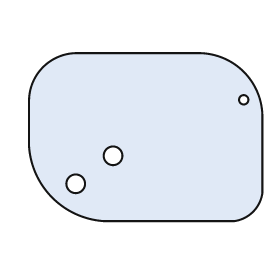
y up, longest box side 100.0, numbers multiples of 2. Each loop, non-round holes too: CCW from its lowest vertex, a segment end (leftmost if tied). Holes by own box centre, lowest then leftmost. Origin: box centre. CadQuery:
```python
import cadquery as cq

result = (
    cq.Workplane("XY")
    .moveTo(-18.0, -36.0)
    .lineTo(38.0, -36.0)
    .threePointArc((46.0, -32.0), (50.0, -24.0))
    .lineTo(50.0, 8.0)
    .threePointArc((42.0, 28.0), (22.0, 36.0))
    .lineTo(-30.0, 36.0)
    .threePointArc((-44.0, 30.0), (-50.0, 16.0))
    .lineTo(-50.0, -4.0)
    .threePointArc((-40.0, -26.0), (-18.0, -36.0))
    .close()
    .moveTo(-30.0, -20.0)
    .circle(4.0)
    .moveTo(-14.0, -8.0)
    .circle(4.0)
    .moveTo(42.0, 16.0)
    .circle(2.0)
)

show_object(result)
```